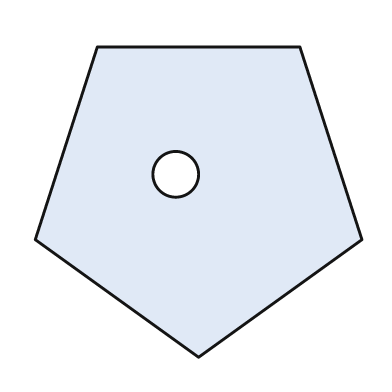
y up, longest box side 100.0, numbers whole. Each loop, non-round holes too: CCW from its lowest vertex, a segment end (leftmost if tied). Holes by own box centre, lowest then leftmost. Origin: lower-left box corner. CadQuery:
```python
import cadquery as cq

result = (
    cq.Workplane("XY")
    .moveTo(50.0, 0.0)
    .lineTo(100.0, 36.0)
    .lineTo(81.0, 95.0)
    .lineTo(19.0, 95.0)
    .lineTo(0.0, 36.0)
    .close()
    .moveTo(43.0, 56.0)
    .circle(7.0)
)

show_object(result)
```